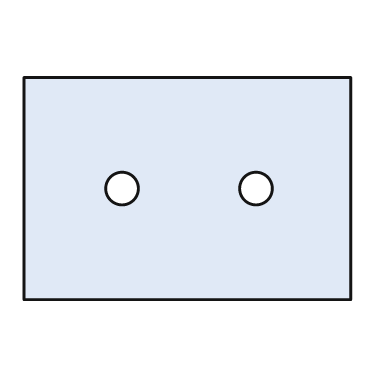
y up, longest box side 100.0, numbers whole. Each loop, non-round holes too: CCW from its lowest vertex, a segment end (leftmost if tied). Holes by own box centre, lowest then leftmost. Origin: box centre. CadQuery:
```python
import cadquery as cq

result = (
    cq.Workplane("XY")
    .moveTo(-50.0, -34.0)
    .lineTo(50.0, -34.0)
    .lineTo(50.0, 34.0)
    .lineTo(-50.0, 34.0)
    .close()
    .moveTo(-20.0, 0.0)
    .circle(5.0)
    .moveTo(21.0, 0.0)
    .circle(5.0)
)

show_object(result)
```